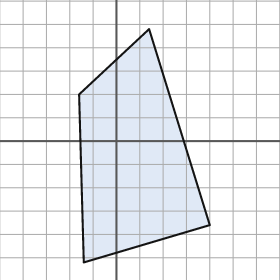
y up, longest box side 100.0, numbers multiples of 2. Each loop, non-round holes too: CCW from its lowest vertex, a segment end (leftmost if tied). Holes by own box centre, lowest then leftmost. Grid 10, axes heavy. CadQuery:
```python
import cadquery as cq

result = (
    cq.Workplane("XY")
    .moveTo(-14.0, -52.0)
    .lineTo(40.0, -36.0)
    .lineTo(14.0, 48.0)
    .lineTo(-16.0, 20.0)
    .close()
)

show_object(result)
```